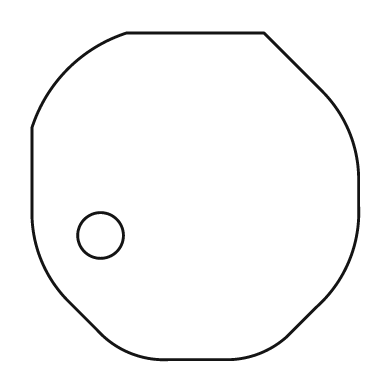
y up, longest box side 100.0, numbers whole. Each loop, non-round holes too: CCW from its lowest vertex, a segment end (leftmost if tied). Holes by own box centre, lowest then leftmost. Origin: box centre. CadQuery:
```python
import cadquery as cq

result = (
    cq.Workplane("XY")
    .moveTo(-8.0, -50.0)
    .lineTo(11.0, -50.0)
    .threePointArc((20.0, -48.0), (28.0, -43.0))
    .lineTo(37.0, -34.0)
    .threePointArc((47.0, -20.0), (50.0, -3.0))
    .lineTo(50.0, 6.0)
    .threePointArc((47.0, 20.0), (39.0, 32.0))
    .lineTo(21.0, 50.0)
    .lineTo(-21.0, 50.0)
    .threePointArc((-39.0, 39.0), (-50.0, 21.0))
    .lineTo(-50.0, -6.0)
    .threePointArc((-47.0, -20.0), (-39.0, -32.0))
    .lineTo(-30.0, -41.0)
    .threePointArc((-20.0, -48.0), (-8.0, -50.0))
    .close()
    .moveTo(-29.0, -12.0)
    .circle(7.0)
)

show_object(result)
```